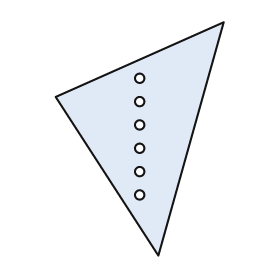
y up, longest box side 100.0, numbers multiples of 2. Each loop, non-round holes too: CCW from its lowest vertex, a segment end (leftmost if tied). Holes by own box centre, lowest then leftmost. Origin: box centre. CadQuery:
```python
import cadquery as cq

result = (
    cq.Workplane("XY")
    .moveTo(8.0, -50.0)
    .lineTo(36.0, 50.0)
    .lineTo(-36.0, 18.0)
    .close()
    .moveTo(0.0, -24.0)
    .circle(2.0)
    .moveTo(0.0, -14.0)
    .circle(2.0)
    .moveTo(0.0, -4.0)
    .circle(2.0)
    .moveTo(0.0, 6.0)
    .circle(2.0)
    .moveTo(0.0, 16.0)
    .circle(2.0)
    .moveTo(0.0, 26.0)
    .circle(2.0)
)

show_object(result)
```